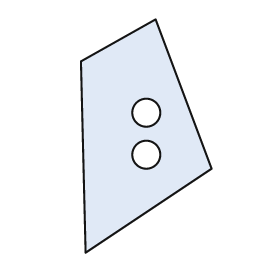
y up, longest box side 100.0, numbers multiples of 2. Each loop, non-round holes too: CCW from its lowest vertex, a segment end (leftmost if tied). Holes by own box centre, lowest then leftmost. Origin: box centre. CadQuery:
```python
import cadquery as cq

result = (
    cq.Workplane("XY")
    .moveTo(-26.0, -50.0)
    .lineTo(28.0, -14.0)
    .lineTo(4.0, 50.0)
    .lineTo(-28.0, 32.0)
    .close()
    .moveTo(0.0, -8.0)
    .circle(6.0)
    .moveTo(0.0, 10.0)
    .circle(6.0)
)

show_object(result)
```